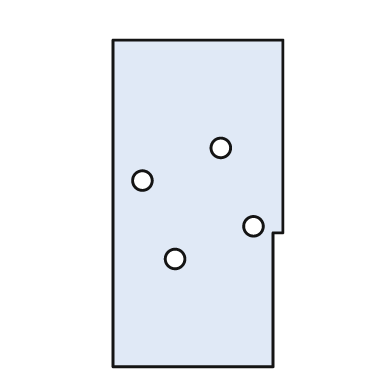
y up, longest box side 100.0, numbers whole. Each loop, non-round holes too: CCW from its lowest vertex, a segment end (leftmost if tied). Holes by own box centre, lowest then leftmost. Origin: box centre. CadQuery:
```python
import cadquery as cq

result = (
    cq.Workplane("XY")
    .moveTo(-26.0, -50.0)
    .lineTo(23.0, -50.0)
    .lineTo(23.0, -9.0)
    .lineTo(26.0, -9.0)
    .lineTo(26.0, 50.0)
    .lineTo(-26.0, 50.0)
    .close()
    .moveTo(-7.0, -17.0)
    .circle(3.0)
    .moveTo(17.0, -7.0)
    .circle(3.0)
    .moveTo(-17.0, 7.0)
    .circle(3.0)
    .moveTo(7.0, 17.0)
    .circle(3.0)
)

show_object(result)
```